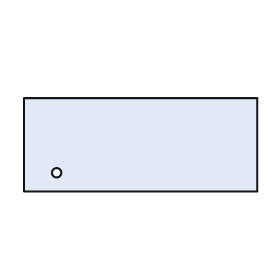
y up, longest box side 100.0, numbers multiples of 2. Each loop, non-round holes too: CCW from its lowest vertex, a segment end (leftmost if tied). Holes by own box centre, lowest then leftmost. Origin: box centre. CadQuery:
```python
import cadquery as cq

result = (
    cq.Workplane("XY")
    .moveTo(-50.0, -20.0)
    .lineTo(50.0, -20.0)
    .lineTo(50.0, 20.0)
    .lineTo(-50.0, 20.0)
    .close()
    .moveTo(-36.0, -12.0)
    .circle(2.0)
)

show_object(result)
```